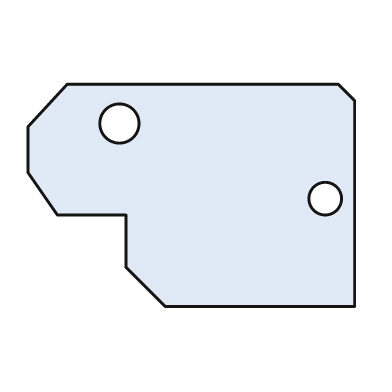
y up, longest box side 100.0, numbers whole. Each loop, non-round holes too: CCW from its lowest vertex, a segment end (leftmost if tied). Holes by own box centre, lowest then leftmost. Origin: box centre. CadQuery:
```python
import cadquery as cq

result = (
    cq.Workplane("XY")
    .moveTo(-8.0, -34.0)
    .lineTo(50.0, -34.0)
    .lineTo(50.0, 29.0)
    .lineTo(45.0, 34.0)
    .lineTo(-38.0, 34.0)
    .lineTo(-50.0, 21.0)
    .lineTo(-50.0, 7.0)
    .lineTo(-41.0, -6.0)
    .lineTo(-20.0, -6.0)
    .lineTo(-20.0, -22.0)
    .close()
    .moveTo(41.0, -1.0)
    .circle(5.0)
    .moveTo(-22.0, 22.0)
    .circle(6.0)
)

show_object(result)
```